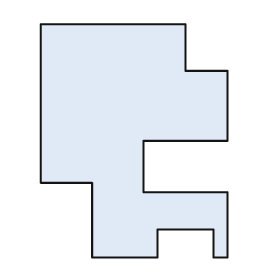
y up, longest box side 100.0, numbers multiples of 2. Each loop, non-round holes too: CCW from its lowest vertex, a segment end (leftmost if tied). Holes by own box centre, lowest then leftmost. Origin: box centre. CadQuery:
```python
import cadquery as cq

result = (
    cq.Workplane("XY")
    .moveTo(-18.0, -50.0)
    .lineTo(10.0, -50.0)
    .lineTo(10.0, -38.0)
    .lineTo(34.0, -38.0)
    .lineTo(34.0, -50.0)
    .lineTo(40.0, -50.0)
    .lineTo(40.0, -22.0)
    .lineTo(4.0, -22.0)
    .lineTo(4.0, 0.0)
    .lineTo(40.0, 0.0)
    .lineTo(40.0, 30.0)
    .lineTo(22.0, 30.0)
    .lineTo(22.0, 50.0)
    .lineTo(-40.0, 50.0)
    .lineTo(-40.0, -18.0)
    .lineTo(-18.0, -18.0)
    .close()
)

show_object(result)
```